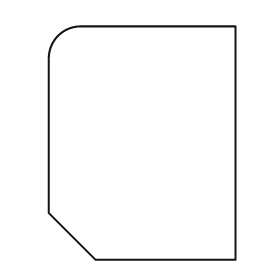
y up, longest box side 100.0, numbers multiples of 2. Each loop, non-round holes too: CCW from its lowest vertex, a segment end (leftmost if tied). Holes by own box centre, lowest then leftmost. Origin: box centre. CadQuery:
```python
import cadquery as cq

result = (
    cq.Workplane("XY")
    .moveTo(-20.0, -50.0)
    .lineTo(40.0, -50.0)
    .lineTo(40.0, 50.0)
    .lineTo(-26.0, 50.0)
    .threePointArc((-36.0, 46.0), (-40.0, 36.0))
    .lineTo(-40.0, -30.0)
    .close()
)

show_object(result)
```